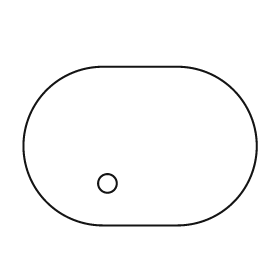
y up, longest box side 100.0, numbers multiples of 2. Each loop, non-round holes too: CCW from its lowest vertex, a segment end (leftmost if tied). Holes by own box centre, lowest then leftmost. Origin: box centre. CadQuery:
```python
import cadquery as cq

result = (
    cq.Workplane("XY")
    .moveTo(-16.0, -34.0)
    .lineTo(16.0, -34.0)
    .threePointArc((50.0, 0.0), (16.0, 34.0))
    .lineTo(-16.0, 34.0)
    .threePointArc((-50.0, 0.0), (-16.0, -34.0))
    .close()
    .moveTo(-14.0, -16.0)
    .circle(4.0)
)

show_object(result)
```